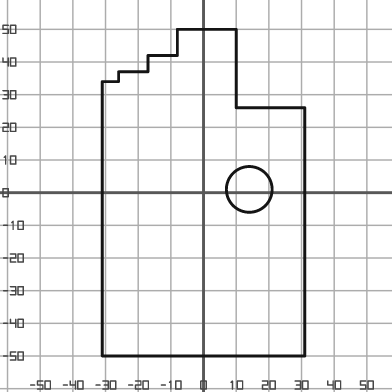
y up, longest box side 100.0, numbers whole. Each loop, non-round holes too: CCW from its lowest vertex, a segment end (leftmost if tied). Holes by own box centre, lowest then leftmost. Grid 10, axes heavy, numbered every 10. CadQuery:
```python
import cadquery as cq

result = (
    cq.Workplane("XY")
    .moveTo(-31.0, -50.0)
    .lineTo(31.0, -50.0)
    .lineTo(31.0, 26.0)
    .lineTo(10.0, 26.0)
    .lineTo(10.0, 50.0)
    .lineTo(-8.0, 50.0)
    .lineTo(-8.0, 42.0)
    .lineTo(-17.0, 42.0)
    .lineTo(-17.0, 37.0)
    .lineTo(-26.0, 37.0)
    .lineTo(-26.0, 34.0)
    .lineTo(-31.0, 34.0)
    .close()
    .moveTo(14.0, 1.0)
    .circle(7.0)
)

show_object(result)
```